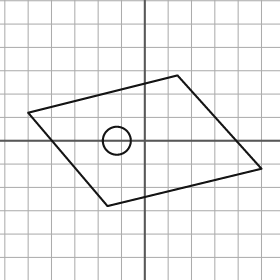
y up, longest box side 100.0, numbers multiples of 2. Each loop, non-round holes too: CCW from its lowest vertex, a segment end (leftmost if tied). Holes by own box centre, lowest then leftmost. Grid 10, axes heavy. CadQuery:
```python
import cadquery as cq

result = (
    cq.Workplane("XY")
    .moveTo(-16.0, -28.0)
    .lineTo(50.0, -12.0)
    .lineTo(14.0, 28.0)
    .lineTo(-50.0, 12.0)
    .close()
    .moveTo(-12.0, 0.0)
    .circle(6.0)
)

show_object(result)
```